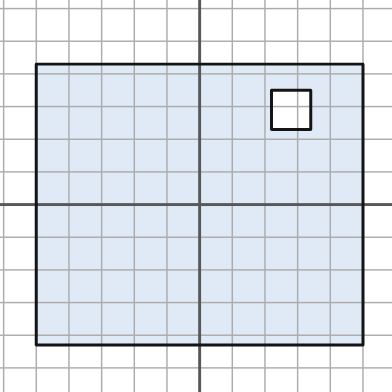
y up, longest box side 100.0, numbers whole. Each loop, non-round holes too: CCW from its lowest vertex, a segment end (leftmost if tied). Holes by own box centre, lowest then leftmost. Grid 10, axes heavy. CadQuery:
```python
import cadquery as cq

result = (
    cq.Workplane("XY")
    .moveTo(-50.0, -43.0)
    .lineTo(50.0, -43.0)
    .lineTo(50.0, 43.0)
    .lineTo(-50.0, 43.0)
    .close()
    .moveTo(22.0, 23.0)
    .lineTo(34.0, 23.0)
    .lineTo(34.0, 35.0)
    .lineTo(22.0, 35.0)
    .close()
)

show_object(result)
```